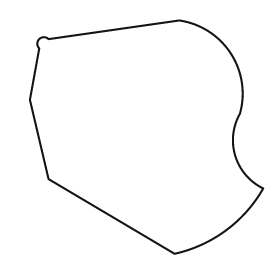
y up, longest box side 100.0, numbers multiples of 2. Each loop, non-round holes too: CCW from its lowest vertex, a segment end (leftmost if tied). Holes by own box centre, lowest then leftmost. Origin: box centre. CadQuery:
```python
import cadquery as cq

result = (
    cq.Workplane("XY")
    .moveTo(12.0, -50.0)
    .threePointArc((34.0, -40.0), (50.0, -22.0))
    .threePointArc((38.0, -8.0), (40.0, 10.0))
    .threePointArc((36.0, 36.0), (14.0, 50.0))
    .lineTo(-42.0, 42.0)
    .threePointArc((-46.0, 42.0), (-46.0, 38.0))
    .lineTo(-50.0, 16.0)
    .lineTo(-42.0, -18.0)
    .close()
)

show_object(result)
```